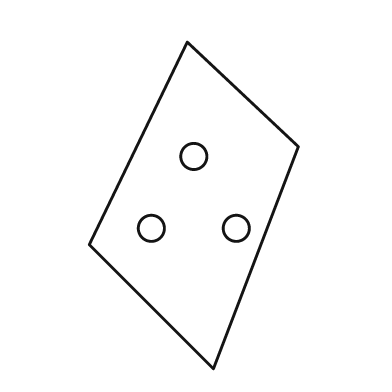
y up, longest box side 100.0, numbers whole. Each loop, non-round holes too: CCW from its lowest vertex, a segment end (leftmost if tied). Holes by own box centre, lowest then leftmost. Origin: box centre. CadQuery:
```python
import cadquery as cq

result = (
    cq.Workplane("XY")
    .moveTo(6.0, -50.0)
    .lineTo(32.0, 18.0)
    .lineTo(-2.0, 50.0)
    .lineTo(-32.0, -12.0)
    .close()
    .moveTo(-13.0, -7.0)
    .circle(4.0)
    .moveTo(13.0, -7.0)
    .circle(4.0)
    .moveTo(0.0, 15.0)
    .circle(4.0)
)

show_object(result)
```